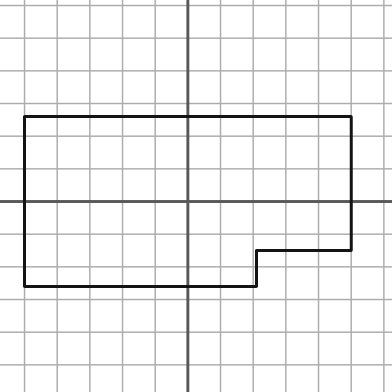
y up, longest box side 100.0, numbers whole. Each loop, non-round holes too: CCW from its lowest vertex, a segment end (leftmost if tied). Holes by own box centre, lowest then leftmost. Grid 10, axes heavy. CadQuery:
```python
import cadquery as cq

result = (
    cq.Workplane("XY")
    .moveTo(-50.0, -26.0)
    .lineTo(21.0, -26.0)
    .lineTo(21.0, -15.0)
    .lineTo(50.0, -15.0)
    .lineTo(50.0, 26.0)
    .lineTo(-50.0, 26.0)
    .close()
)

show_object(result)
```